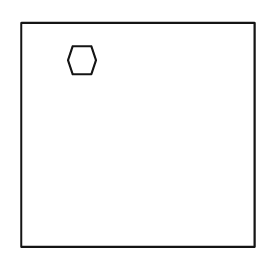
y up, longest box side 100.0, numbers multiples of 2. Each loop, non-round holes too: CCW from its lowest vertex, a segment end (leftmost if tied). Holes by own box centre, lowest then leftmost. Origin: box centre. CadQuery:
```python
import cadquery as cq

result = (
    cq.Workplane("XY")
    .moveTo(-50.0, -48.0)
    .lineTo(50.0, -48.0)
    .lineTo(50.0, 48.0)
    .lineTo(-50.0, 48.0)
    .close()
    .moveTo(-28.0, 26.0)
    .lineTo(-20.0, 26.0)
    .lineTo(-18.0, 32.0)
    .lineTo(-20.0, 38.0)
    .lineTo(-28.0, 38.0)
    .lineTo(-30.0, 32.0)
    .close()
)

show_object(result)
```